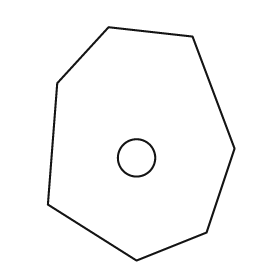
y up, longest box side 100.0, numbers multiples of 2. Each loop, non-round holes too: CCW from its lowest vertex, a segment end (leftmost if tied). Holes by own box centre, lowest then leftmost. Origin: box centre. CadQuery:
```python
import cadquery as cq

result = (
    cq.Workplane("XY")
    .moveTo(-2.0, -50.0)
    .lineTo(28.0, -38.0)
    .lineTo(40.0, -2.0)
    .lineTo(22.0, 46.0)
    .lineTo(-14.0, 50.0)
    .lineTo(-36.0, 26.0)
    .lineTo(-40.0, -26.0)
    .close()
    .moveTo(-2.0, -6.0)
    .circle(8.0)
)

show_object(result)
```